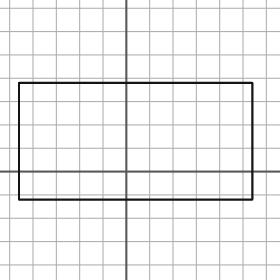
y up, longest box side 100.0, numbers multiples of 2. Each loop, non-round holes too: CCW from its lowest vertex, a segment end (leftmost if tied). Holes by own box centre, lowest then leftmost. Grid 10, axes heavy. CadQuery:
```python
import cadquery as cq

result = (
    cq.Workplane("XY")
    .moveTo(-46.0, -12.0)
    .lineTo(54.0, -12.0)
    .lineTo(54.0, 38.0)
    .lineTo(-46.0, 38.0)
    .close()
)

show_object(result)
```